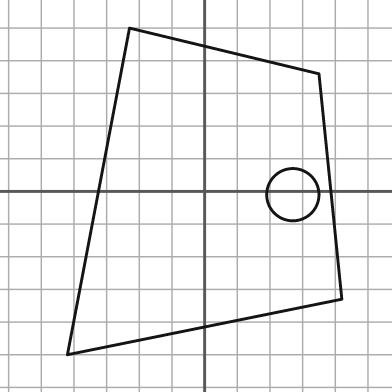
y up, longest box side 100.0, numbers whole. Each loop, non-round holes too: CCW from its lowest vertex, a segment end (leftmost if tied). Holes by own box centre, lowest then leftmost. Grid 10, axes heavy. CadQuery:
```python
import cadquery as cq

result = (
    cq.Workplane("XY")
    .moveTo(-42.0, -50.0)
    .lineTo(42.0, -33.0)
    .lineTo(35.0, 36.0)
    .lineTo(-23.0, 50.0)
    .close()
    .moveTo(27.0, -1.0)
    .circle(8.0)
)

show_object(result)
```